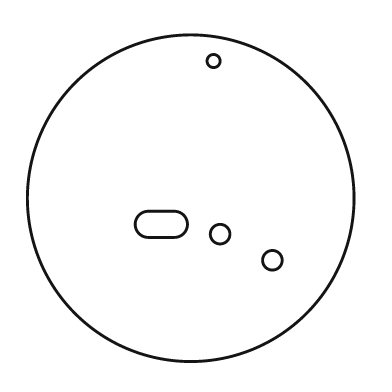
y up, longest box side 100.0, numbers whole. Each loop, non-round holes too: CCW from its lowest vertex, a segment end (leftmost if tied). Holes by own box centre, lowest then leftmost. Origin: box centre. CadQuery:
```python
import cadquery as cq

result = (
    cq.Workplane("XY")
    .moveTo(0.0, 0.0)
    .circle(50.0)
    .moveTo(25.0, -19.0)
    .circle(3.0)
    .moveTo(9.0, -11.0)
    .circle(3.0)
    .moveTo(-13.0, -12.0)
    .lineTo(-5.0, -12.0)
    .threePointArc((-1.0, -8.0), (-5.0, -4.0))
    .lineTo(-13.0, -4.0)
    .threePointArc((-17.0, -8.0), (-13.0, -12.0))
    .close()
    .moveTo(7.0, 42.0)
    .circle(2.0)
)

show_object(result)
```